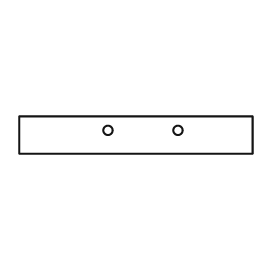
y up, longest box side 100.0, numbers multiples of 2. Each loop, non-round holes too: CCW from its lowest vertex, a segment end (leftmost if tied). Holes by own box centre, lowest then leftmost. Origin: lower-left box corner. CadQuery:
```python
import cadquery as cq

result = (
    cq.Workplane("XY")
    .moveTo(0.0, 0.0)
    .lineTo(100.0, 0.0)
    .lineTo(100.0, 16.0)
    .lineTo(0.0, 16.0)
    .close()
    .moveTo(38.0, 10.0)
    .circle(2.0)
    .moveTo(68.0, 10.0)
    .circle(2.0)
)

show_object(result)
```